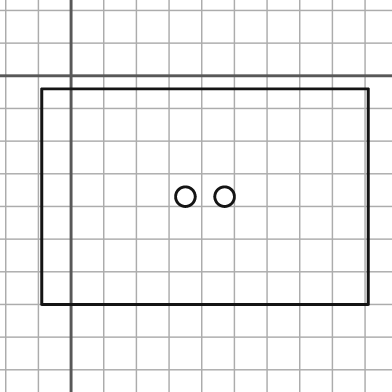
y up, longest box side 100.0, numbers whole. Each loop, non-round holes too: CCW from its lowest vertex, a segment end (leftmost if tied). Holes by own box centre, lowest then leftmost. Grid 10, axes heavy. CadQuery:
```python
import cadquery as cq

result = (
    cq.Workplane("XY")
    .moveTo(-9.0, -70.0)
    .lineTo(91.0, -70.0)
    .lineTo(91.0, -4.0)
    .lineTo(-9.0, -4.0)
    .close()
    .moveTo(35.0, -37.0)
    .circle(3.0)
    .moveTo(47.0, -37.0)
    .circle(3.0)
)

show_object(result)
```